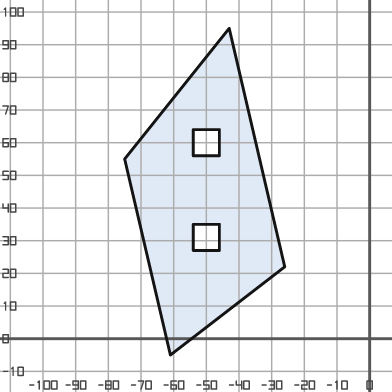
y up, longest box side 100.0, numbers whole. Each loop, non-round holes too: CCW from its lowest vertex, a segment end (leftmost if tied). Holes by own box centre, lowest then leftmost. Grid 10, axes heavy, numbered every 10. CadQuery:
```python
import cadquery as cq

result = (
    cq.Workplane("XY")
    .moveTo(-61.0, -5.0)
    .lineTo(-26.0, 22.0)
    .lineTo(-43.0, 95.0)
    .lineTo(-75.0, 55.0)
    .close()
    .moveTo(-54.0, 27.0)
    .lineTo(-46.0, 27.0)
    .lineTo(-46.0, 35.0)
    .lineTo(-54.0, 35.0)
    .close()
    .moveTo(-54.0, 56.0)
    .lineTo(-46.0, 56.0)
    .lineTo(-46.0, 64.0)
    .lineTo(-54.0, 64.0)
    .close()
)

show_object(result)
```